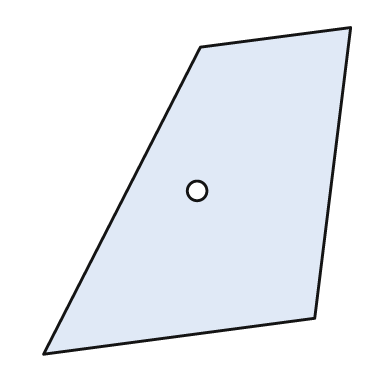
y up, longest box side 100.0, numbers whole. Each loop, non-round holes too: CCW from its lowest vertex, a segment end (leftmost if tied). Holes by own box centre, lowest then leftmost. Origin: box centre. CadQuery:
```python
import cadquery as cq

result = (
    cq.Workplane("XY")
    .moveTo(-47.0, -50.0)
    .lineTo(36.0, -39.0)
    .lineTo(47.0, 50.0)
    .lineTo(1.0, 44.0)
    .close()
    .moveTo(0.0, 0.0)
    .circle(3.0)
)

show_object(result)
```